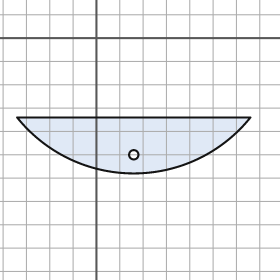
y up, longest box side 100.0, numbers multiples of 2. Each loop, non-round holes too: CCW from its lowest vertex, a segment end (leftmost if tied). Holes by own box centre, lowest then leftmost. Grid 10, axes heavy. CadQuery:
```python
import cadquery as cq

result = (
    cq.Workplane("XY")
    .moveTo(-34.0, -34.0)
    .threePointArc((16.0, -58.0), (66.0, -34.0))
    .close()
    .moveTo(16.0, -50.0)
    .circle(2.0)
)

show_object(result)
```